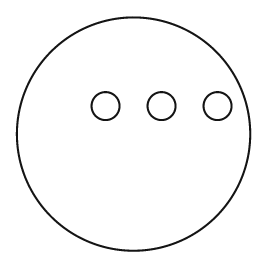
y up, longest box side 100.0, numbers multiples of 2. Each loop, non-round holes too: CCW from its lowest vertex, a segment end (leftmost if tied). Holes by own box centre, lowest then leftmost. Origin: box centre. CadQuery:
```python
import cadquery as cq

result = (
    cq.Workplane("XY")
    .moveTo(0.0, 0.0)
    .circle(50.0)
    .moveTo(-12.0, 12.0)
    .circle(6.0)
    .moveTo(12.0, 12.0)
    .circle(6.0)
    .moveTo(36.0, 12.0)
    .circle(6.0)
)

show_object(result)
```